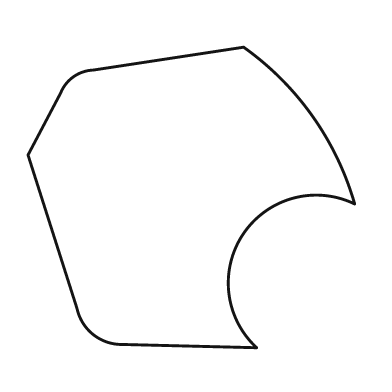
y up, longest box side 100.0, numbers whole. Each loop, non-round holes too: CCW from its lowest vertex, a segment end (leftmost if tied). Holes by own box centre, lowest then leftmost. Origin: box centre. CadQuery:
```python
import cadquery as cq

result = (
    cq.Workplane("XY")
    .moveTo(20.0, -46.0)
    .threePointArc((16.0, -11.0), (50.0, -2.0))
    .threePointArc((37.0, 25.0), (16.0, 46.0))
    .lineTo(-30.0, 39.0)
    .threePointArc((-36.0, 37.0), (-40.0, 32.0))
    .lineTo(-50.0, 13.0)
    .lineTo(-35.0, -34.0)
    .threePointArc((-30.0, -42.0), (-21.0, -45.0))
    .close()
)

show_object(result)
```